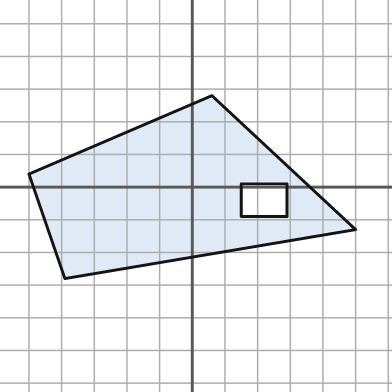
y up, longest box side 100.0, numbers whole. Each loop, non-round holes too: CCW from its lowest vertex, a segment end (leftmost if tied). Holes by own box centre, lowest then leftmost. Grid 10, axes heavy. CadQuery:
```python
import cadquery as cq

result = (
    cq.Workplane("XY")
    .moveTo(-39.0, -28.0)
    .lineTo(50.0, -13.0)
    .lineTo(6.0, 28.0)
    .lineTo(-50.0, 4.0)
    .close()
    .moveTo(15.0, -9.0)
    .lineTo(29.0, -9.0)
    .lineTo(29.0, 1.0)
    .lineTo(15.0, 1.0)
    .close()
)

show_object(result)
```